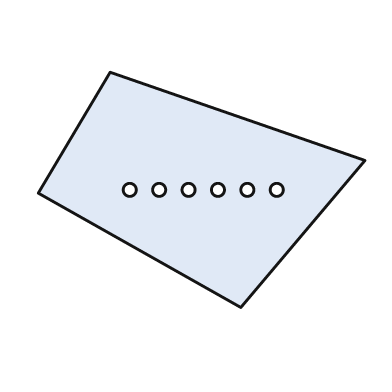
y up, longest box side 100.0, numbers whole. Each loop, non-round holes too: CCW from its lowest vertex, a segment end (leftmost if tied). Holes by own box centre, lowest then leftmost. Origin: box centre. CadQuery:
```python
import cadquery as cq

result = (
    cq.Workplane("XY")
    .moveTo(12.0, -36.0)
    .lineTo(50.0, 9.0)
    .lineTo(-28.0, 36.0)
    .lineTo(-50.0, -1.0)
    .close()
    .moveTo(-22.0, 0.0)
    .circle(2.0)
    .moveTo(-13.0, 0.0)
    .circle(2.0)
    .moveTo(-4.0, 0.0)
    .circle(2.0)
    .moveTo(5.0, 0.0)
    .circle(2.0)
    .moveTo(14.0, 0.0)
    .circle(2.0)
    .moveTo(23.0, 0.0)
    .circle(2.0)
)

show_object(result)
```